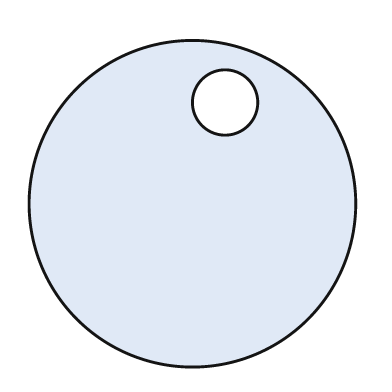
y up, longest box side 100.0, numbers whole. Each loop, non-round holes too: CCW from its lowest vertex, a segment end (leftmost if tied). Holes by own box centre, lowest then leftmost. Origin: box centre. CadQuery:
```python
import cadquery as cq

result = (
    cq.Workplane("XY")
    .moveTo(0.0, 0.0)
    .circle(50.0)
    .moveTo(10.0, 31.0)
    .circle(10.0)
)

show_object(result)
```